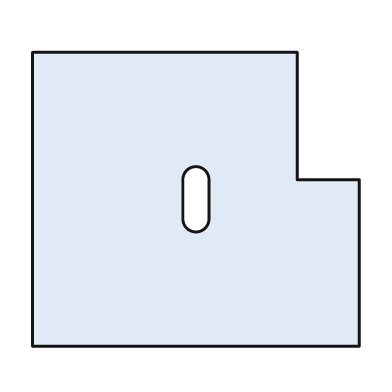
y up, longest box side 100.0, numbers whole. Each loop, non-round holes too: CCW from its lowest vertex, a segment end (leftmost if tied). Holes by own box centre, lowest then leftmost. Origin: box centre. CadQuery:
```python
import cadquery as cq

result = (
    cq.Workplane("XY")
    .moveTo(-50.0, -45.0)
    .lineTo(50.0, -45.0)
    .lineTo(50.0, 6.0)
    .lineTo(31.0, 6.0)
    .lineTo(31.0, 45.0)
    .lineTo(-50.0, 45.0)
    .close()
    .moveTo(-4.0, -6.0)
    .threePointArc((0.0, -10.0), (4.0, -6.0))
    .lineTo(4.0, 6.0)
    .threePointArc((0.0, 10.0), (-4.0, 6.0))
    .close()
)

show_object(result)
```